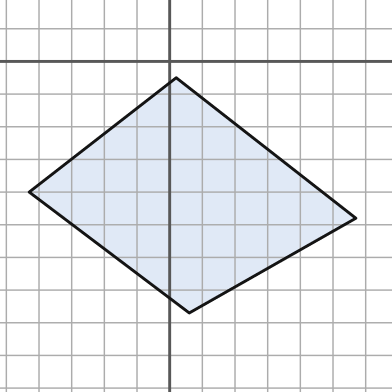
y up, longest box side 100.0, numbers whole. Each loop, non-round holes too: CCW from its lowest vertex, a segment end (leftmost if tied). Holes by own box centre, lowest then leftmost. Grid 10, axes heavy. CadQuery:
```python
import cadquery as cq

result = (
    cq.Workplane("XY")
    .moveTo(6.0, -77.0)
    .lineTo(57.0, -48.0)
    .lineTo(2.0, -5.0)
    .lineTo(-43.0, -40.0)
    .close()
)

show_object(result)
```